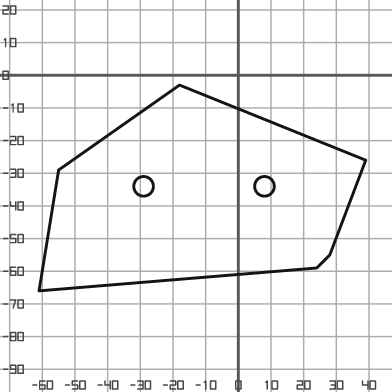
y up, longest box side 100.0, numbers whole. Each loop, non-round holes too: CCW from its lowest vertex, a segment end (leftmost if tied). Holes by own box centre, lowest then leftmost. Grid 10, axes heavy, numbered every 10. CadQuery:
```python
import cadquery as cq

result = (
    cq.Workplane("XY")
    .moveTo(-61.0, -66.0)
    .lineTo(24.0, -59.0)
    .lineTo(28.0, -55.0)
    .lineTo(39.0, -26.0)
    .lineTo(-18.0, -3.0)
    .lineTo(-55.0, -29.0)
    .close()
    .moveTo(-29.0, -34.0)
    .circle(3.0)
    .moveTo(8.0, -34.0)
    .circle(3.0)
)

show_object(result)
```